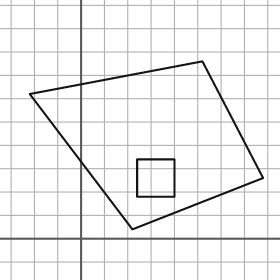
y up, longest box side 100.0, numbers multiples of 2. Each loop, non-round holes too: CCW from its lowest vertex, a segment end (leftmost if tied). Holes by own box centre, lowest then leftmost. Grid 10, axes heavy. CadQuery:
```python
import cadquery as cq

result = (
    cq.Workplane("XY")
    .moveTo(22.0, 4.0)
    .lineTo(78.0, 26.0)
    .lineTo(52.0, 76.0)
    .lineTo(-22.0, 62.0)
    .close()
    .moveTo(24.0, 18.0)
    .lineTo(40.0, 18.0)
    .lineTo(40.0, 34.0)
    .lineTo(24.0, 34.0)
    .close()
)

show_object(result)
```